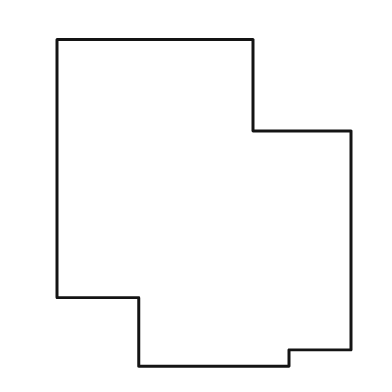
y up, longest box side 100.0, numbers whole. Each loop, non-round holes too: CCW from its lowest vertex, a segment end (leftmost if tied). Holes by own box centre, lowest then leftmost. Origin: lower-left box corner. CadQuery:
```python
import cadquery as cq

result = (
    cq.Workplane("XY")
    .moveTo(25.0, 0.0)
    .lineTo(71.0, 0.0)
    .lineTo(71.0, 5.0)
    .lineTo(90.0, 5.0)
    .lineTo(90.0, 72.0)
    .lineTo(60.0, 72.0)
    .lineTo(60.0, 100.0)
    .lineTo(0.0, 100.0)
    .lineTo(0.0, 21.0)
    .lineTo(25.0, 21.0)
    .close()
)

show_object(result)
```